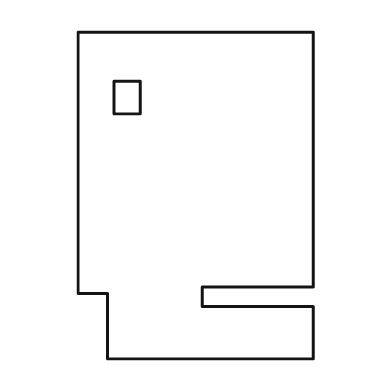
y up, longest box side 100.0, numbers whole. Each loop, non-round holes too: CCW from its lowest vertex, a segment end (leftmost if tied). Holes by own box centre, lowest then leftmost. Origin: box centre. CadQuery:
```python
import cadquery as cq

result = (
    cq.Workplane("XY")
    .moveTo(-27.0, -50.0)
    .lineTo(36.0, -50.0)
    .lineTo(36.0, -34.0)
    .lineTo(2.0, -34.0)
    .lineTo(2.0, -28.0)
    .lineTo(36.0, -28.0)
    .lineTo(36.0, 50.0)
    .lineTo(-36.0, 50.0)
    .lineTo(-36.0, -30.0)
    .lineTo(-27.0, -30.0)
    .close()
    .moveTo(-25.0, 25.0)
    .lineTo(-17.0, 25.0)
    .lineTo(-17.0, 35.0)
    .lineTo(-25.0, 35.0)
    .close()
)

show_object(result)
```